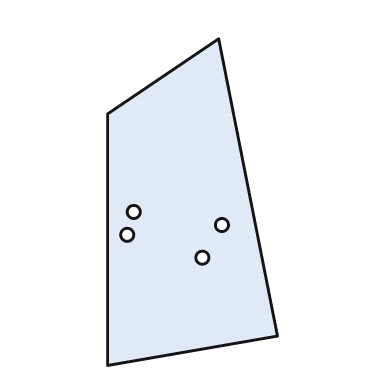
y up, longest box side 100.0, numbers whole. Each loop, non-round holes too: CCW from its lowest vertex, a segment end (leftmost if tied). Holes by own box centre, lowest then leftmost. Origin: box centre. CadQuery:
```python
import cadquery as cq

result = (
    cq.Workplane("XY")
    .moveTo(-26.0, -50.0)
    .lineTo(26.0, -41.0)
    .lineTo(8.0, 50.0)
    .lineTo(-26.0, 27.0)
    .close()
    .moveTo(3.0, -17.0)
    .circle(2.0)
    .moveTo(-20.0, -10.0)
    .circle(2.0)
    .moveTo(9.0, -7.0)
    .circle(2.0)
    .moveTo(-18.0, -3.0)
    .circle(2.0)
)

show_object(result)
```